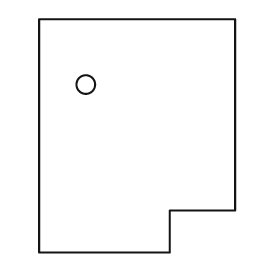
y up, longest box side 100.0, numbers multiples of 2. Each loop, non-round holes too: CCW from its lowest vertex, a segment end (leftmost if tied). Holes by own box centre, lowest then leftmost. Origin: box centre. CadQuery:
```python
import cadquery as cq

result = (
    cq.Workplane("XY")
    .moveTo(-42.0, -50.0)
    .lineTo(14.0, -50.0)
    .lineTo(14.0, -32.0)
    .lineTo(42.0, -32.0)
    .lineTo(42.0, 50.0)
    .lineTo(-42.0, 50.0)
    .close()
    .moveTo(-22.0, 22.0)
    .circle(4.0)
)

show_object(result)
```